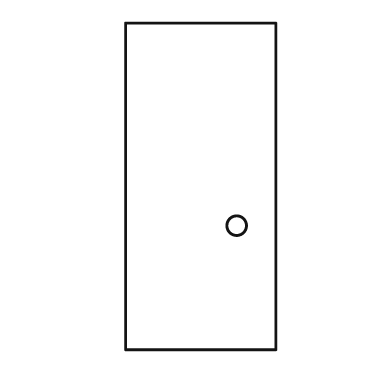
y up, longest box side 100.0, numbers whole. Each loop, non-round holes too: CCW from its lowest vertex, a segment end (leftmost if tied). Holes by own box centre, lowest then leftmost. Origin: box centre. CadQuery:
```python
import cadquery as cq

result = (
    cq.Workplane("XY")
    .moveTo(-23.0, -50.0)
    .lineTo(23.0, -50.0)
    .lineTo(23.0, 50.0)
    .lineTo(-23.0, 50.0)
    .close()
    .moveTo(11.0, -12.0)
    .circle(3.0)
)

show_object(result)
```